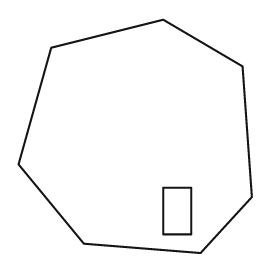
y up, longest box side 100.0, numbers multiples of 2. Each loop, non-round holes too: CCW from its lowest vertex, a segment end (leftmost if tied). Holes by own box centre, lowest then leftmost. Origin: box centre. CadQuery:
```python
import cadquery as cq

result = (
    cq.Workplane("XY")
    .moveTo(28.0, -50.0)
    .lineTo(50.0, -26.0)
    .lineTo(46.0, 30.0)
    .lineTo(12.0, 50.0)
    .lineTo(-36.0, 38.0)
    .lineTo(-50.0, -12.0)
    .lineTo(-22.0, -46.0)
    .close()
    .moveTo(12.0, -42.0)
    .lineTo(24.0, -42.0)
    .lineTo(24.0, -22.0)
    .lineTo(12.0, -22.0)
    .close()
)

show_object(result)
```